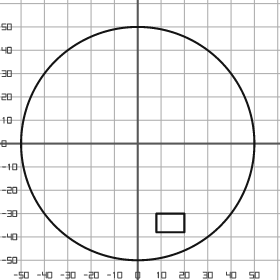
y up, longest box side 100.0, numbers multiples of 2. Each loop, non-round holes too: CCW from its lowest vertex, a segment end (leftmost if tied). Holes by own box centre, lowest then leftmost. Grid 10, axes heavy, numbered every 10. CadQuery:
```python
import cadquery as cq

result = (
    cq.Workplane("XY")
    .moveTo(0.0, 0.0)
    .circle(50.0)
    .moveTo(8.0, -38.0)
    .lineTo(20.0, -38.0)
    .lineTo(20.0, -30.0)
    .lineTo(8.0, -30.0)
    .close()
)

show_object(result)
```